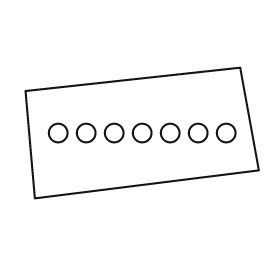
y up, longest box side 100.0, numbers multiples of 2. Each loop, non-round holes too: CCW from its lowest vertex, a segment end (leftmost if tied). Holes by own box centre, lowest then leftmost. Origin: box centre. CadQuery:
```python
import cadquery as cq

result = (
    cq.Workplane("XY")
    .moveTo(-46.0, -28.0)
    .lineTo(50.0, -16.0)
    .lineTo(42.0, 28.0)
    .lineTo(-50.0, 18.0)
    .close()
    .moveTo(-36.0, 0.0)
    .circle(4.0)
    .moveTo(-24.0, 0.0)
    .circle(4.0)
    .moveTo(-12.0, 0.0)
    .circle(4.0)
    .moveTo(0.0, 0.0)
    .circle(4.0)
    .moveTo(12.0, 0.0)
    .circle(4.0)
    .moveTo(24.0, 0.0)
    .circle(4.0)
    .moveTo(36.0, 0.0)
    .circle(4.0)
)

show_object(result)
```